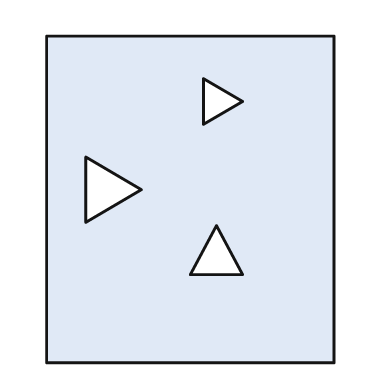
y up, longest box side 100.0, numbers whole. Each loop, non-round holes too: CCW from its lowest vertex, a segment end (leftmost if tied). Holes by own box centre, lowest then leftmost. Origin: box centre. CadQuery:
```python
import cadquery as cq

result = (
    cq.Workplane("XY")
    .moveTo(-44.0, -50.0)
    .lineTo(44.0, -50.0)
    .lineTo(44.0, 50.0)
    .lineTo(-44.0, 50.0)
    .close()
    .moveTo(0.0, -23.0)
    .lineTo(16.0, -23.0)
    .lineTo(8.0, -8.0)
    .close()
    .moveTo(-32.0, -7.0)
    .lineTo(-15.0, 3.0)
    .lineTo(-32.0, 13.0)
    .close()
    .moveTo(4.0, 23.0)
    .lineTo(16.0, 30.0)
    .lineTo(4.0, 37.0)
    .close()
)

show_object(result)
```